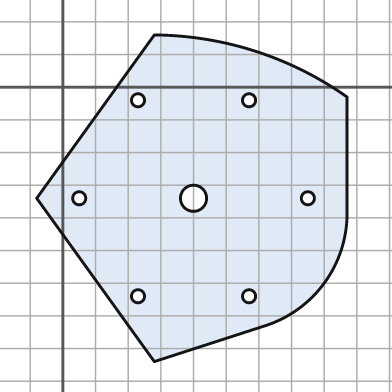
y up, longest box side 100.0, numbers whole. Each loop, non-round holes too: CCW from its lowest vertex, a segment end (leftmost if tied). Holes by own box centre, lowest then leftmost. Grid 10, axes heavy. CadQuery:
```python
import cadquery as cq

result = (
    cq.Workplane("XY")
    .moveTo(28.0, -84.0)
    .lineTo(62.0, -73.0)
    .threePointArc((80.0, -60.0), (87.0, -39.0))
    .lineTo(87.0, -3.0)
    .threePointArc((59.0, 11.0), (28.0, 16.0))
    .lineTo(-8.0, -34.0)
    .close()
    .moveTo(23.0, -64.0)
    .circle(2.0)
    .moveTo(57.0, -64.0)
    .circle(2.0)
    .moveTo(5.0, -34.0)
    .circle(2.0)
    .moveTo(40.0, -34.0)
    .circle(4.0)
    .moveTo(75.0, -34.0)
    .circle(2.0)
    .moveTo(23.0, -4.0)
    .circle(2.0)
    .moveTo(57.0, -4.0)
    .circle(2.0)
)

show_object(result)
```